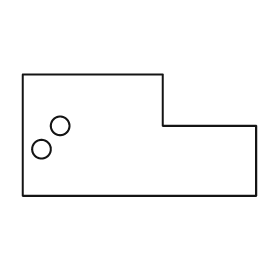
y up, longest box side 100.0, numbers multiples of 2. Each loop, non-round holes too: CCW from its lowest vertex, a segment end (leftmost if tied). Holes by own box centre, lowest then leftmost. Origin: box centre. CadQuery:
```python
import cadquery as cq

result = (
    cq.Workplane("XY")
    .moveTo(-50.0, -26.0)
    .lineTo(50.0, -26.0)
    .lineTo(50.0, 4.0)
    .lineTo(10.0, 4.0)
    .lineTo(10.0, 26.0)
    .lineTo(-50.0, 26.0)
    .close()
    .moveTo(-42.0, -6.0)
    .circle(4.0)
    .moveTo(-34.0, 4.0)
    .circle(4.0)
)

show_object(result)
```